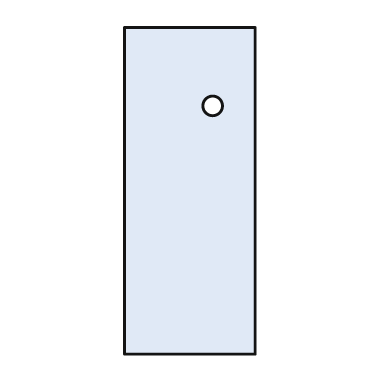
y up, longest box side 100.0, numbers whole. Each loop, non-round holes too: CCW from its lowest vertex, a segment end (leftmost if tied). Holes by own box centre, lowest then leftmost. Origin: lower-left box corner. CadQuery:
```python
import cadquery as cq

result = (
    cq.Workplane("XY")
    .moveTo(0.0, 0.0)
    .lineTo(40.0, 0.0)
    .lineTo(40.0, 100.0)
    .lineTo(0.0, 100.0)
    .close()
    .moveTo(27.0, 76.0)
    .circle(3.0)
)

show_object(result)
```